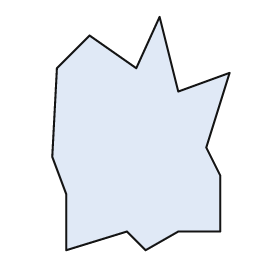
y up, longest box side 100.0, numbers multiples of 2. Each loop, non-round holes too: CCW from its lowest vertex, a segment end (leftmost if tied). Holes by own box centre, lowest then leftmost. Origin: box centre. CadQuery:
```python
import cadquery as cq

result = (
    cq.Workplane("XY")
    .moveTo(-32.0, -50.0)
    .lineTo(-6.0, -42.0)
    .lineTo(2.0, -50.0)
    .lineTo(16.0, -42.0)
    .lineTo(34.0, -42.0)
    .lineTo(34.0, -18.0)
    .lineTo(28.0, -6.0)
    .lineTo(38.0, 26.0)
    .lineTo(16.0, 18.0)
    .lineTo(8.0, 50.0)
    .lineTo(-2.0, 28.0)
    .lineTo(-22.0, 42.0)
    .lineTo(-36.0, 28.0)
    .lineTo(-38.0, -10.0)
    .lineTo(-32.0, -26.0)
    .close()
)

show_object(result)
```